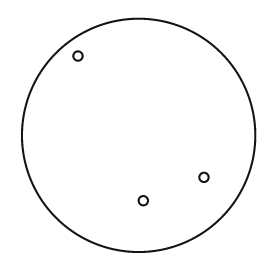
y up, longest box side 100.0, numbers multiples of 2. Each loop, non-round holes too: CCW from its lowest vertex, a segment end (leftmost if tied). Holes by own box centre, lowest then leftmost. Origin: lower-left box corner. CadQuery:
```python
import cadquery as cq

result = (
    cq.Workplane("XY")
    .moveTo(50.0, 50.0)
    .circle(50.0)
    .moveTo(52.0, 22.0)
    .circle(2.0)
    .moveTo(78.0, 32.0)
    .circle(2.0)
    .moveTo(24.0, 84.0)
    .circle(2.0)
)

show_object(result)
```